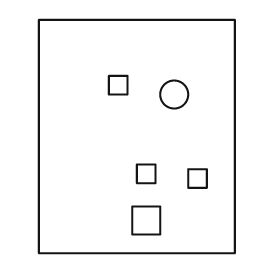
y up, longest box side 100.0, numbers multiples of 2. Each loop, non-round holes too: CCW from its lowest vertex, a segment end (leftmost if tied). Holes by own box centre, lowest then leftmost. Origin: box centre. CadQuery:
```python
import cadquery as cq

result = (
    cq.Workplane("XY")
    .moveTo(-42.0, -50.0)
    .lineTo(42.0, -50.0)
    .lineTo(42.0, 50.0)
    .lineTo(-42.0, 50.0)
    .close()
    .moveTo(-2.0, -42.0)
    .lineTo(10.0, -42.0)
    .lineTo(10.0, -30.0)
    .lineTo(-2.0, -30.0)
    .close()
    .moveTo(22.0, -22.0)
    .lineTo(30.0, -22.0)
    .lineTo(30.0, -14.0)
    .lineTo(22.0, -14.0)
    .close()
    .moveTo(0.0, -20.0)
    .lineTo(8.0, -20.0)
    .lineTo(8.0, -12.0)
    .lineTo(0.0, -12.0)
    .close()
    .moveTo(16.0, 18.0)
    .circle(6.0)
    .moveTo(-12.0, 18.0)
    .lineTo(-4.0, 18.0)
    .lineTo(-4.0, 26.0)
    .lineTo(-12.0, 26.0)
    .close()
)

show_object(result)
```